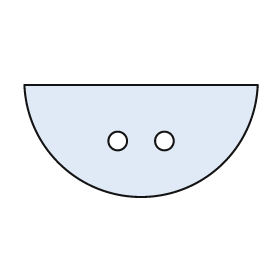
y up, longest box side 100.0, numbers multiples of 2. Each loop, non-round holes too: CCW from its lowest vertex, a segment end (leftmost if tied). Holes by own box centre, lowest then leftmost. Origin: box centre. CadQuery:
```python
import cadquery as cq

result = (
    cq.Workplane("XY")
    .moveTo(-50.0, 24.0)
    .threePointArc((0.0, -24.0), (50.0, 24.0))
    .close()
    .moveTo(-10.0, 0.0)
    .circle(4.0)
    .moveTo(10.0, 0.0)
    .circle(4.0)
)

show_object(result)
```